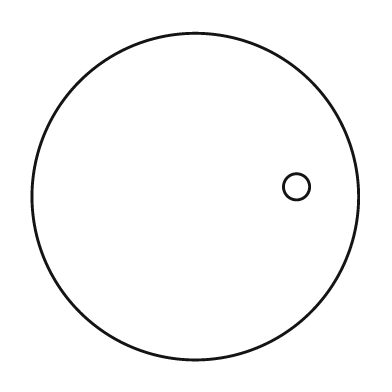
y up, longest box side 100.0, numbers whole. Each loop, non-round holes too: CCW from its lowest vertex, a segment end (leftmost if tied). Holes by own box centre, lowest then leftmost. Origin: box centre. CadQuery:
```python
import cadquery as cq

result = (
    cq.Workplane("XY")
    .moveTo(0.0, 0.0)
    .circle(50.0)
    .moveTo(31.0, 3.0)
    .circle(4.0)
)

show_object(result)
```